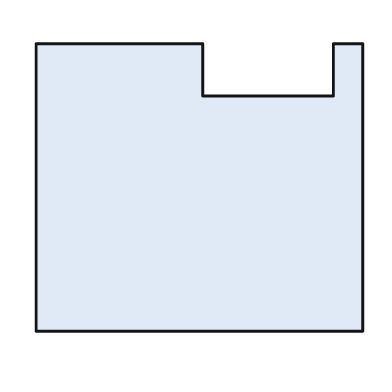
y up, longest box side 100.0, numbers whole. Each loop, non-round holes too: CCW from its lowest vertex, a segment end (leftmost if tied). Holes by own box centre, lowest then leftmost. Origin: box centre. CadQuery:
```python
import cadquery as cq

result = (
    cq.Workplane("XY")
    .moveTo(-50.0, -44.0)
    .lineTo(50.0, -44.0)
    .lineTo(50.0, 44.0)
    .lineTo(41.0, 44.0)
    .lineTo(41.0, 28.0)
    .lineTo(1.0, 28.0)
    .lineTo(1.0, 44.0)
    .lineTo(-50.0, 44.0)
    .close()
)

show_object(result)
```